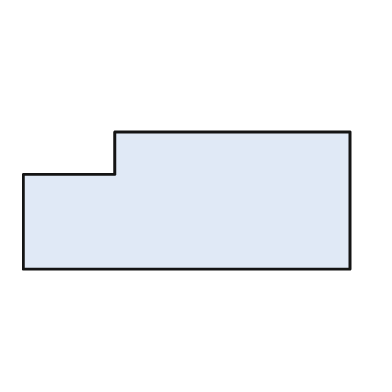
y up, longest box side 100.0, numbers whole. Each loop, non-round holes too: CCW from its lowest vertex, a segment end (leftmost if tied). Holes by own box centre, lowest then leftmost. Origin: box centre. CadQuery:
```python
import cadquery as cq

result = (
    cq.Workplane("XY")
    .moveTo(-50.0, -21.0)
    .lineTo(50.0, -21.0)
    .lineTo(50.0, 21.0)
    .lineTo(-22.0, 21.0)
    .lineTo(-22.0, 8.0)
    .lineTo(-50.0, 8.0)
    .close()
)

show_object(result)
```